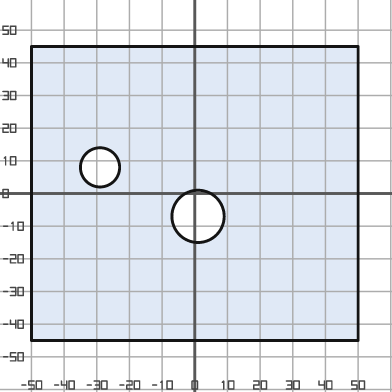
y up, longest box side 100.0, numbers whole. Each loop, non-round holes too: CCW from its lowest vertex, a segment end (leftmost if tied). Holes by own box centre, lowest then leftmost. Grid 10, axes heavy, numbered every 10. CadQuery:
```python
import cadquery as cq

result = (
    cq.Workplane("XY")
    .moveTo(-50.0, -45.0)
    .lineTo(50.0, -45.0)
    .lineTo(50.0, 45.0)
    .lineTo(-50.0, 45.0)
    .close()
    .moveTo(1.0, -7.0)
    .circle(8.0)
    .moveTo(-29.0, 8.0)
    .circle(6.0)
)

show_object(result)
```